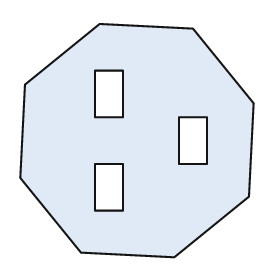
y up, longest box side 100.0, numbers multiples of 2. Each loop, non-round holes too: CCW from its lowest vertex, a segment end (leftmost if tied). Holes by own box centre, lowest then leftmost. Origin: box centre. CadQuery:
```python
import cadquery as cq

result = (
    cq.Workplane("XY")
    .moveTo(16.0, -50.0)
    .lineTo(48.0, -24.0)
    .lineTo(50.0, 16.0)
    .lineTo(24.0, 48.0)
    .lineTo(-16.0, 50.0)
    .lineTo(-48.0, 24.0)
    .lineTo(-50.0, -16.0)
    .lineTo(-24.0, -48.0)
    .close()
    .moveTo(-18.0, -30.0)
    .lineTo(-6.0, -30.0)
    .lineTo(-6.0, -10.0)
    .lineTo(-18.0, -10.0)
    .close()
    .moveTo(18.0, -10.0)
    .lineTo(30.0, -10.0)
    .lineTo(30.0, 10.0)
    .lineTo(18.0, 10.0)
    .close()
    .moveTo(-18.0, 10.0)
    .lineTo(-6.0, 10.0)
    .lineTo(-6.0, 30.0)
    .lineTo(-18.0, 30.0)
    .close()
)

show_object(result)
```